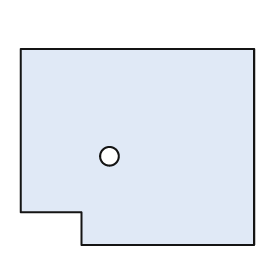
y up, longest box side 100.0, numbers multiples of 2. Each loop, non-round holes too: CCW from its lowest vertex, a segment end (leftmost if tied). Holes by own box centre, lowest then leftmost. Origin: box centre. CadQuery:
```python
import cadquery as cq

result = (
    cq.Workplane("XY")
    .moveTo(-24.0, -42.0)
    .lineTo(50.0, -42.0)
    .lineTo(50.0, 42.0)
    .lineTo(-50.0, 42.0)
    .lineTo(-50.0, -28.0)
    .lineTo(-24.0, -28.0)
    .close()
    .moveTo(-12.0, -4.0)
    .circle(4.0)
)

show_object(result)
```